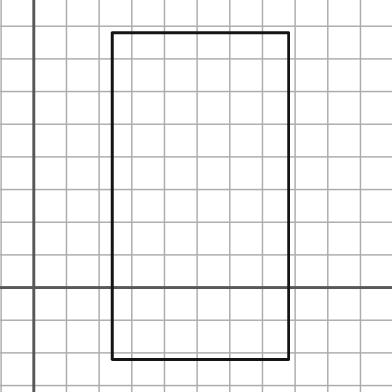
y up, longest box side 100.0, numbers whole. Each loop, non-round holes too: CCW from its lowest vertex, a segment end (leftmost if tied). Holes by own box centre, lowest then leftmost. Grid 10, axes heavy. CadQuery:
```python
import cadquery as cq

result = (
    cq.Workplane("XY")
    .moveTo(24.0, -22.0)
    .lineTo(78.0, -22.0)
    .lineTo(78.0, 78.0)
    .lineTo(24.0, 78.0)
    .close()
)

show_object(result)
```